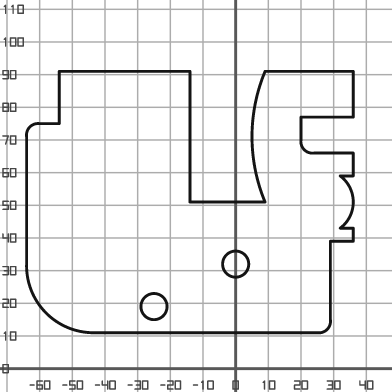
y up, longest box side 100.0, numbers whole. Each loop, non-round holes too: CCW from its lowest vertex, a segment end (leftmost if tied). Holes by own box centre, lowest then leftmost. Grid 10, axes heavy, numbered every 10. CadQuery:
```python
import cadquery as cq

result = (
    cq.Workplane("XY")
    .moveTo(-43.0, 11.0)
    .lineTo(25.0, 11.0)
    .threePointArc((28.0, 12.0), (29.0, 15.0))
    .lineTo(29.0, 39.0)
    .lineTo(36.0, 39.0)
    .lineTo(36.0, 43.0)
    .lineTo(32.0, 43.0)
    .threePointArc((36.0, 51.0), (32.0, 59.0))
    .lineTo(36.0, 59.0)
    .lineTo(36.0, 66.0)
    .lineTo(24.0, 66.0)
    .threePointArc((21.0, 67.0), (20.0, 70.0))
    .lineTo(20.0, 77.0)
    .lineTo(36.0, 77.0)
    .lineTo(36.0, 91.0)
    .lineTo(9.0, 91.0)
    .threePointArc((5.0, 71.0), (9.0, 51.0))
    .lineTo(-14.0, 51.0)
    .lineTo(-14.0, 91.0)
    .lineTo(-54.0, 91.0)
    .lineTo(-54.0, 75.0)
    .lineTo(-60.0, 75.0)
    .threePointArc((-63.0, 74.0), (-64.0, 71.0))
    .lineTo(-64.0, 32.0)
    .threePointArc((-58.0, 17.0), (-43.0, 11.0))
    .close()
    .moveTo(-25.0, 19.0)
    .circle(4.0)
    .moveTo(0.0, 32.0)
    .circle(4.0)
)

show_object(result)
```